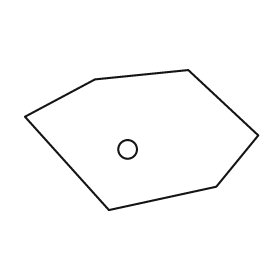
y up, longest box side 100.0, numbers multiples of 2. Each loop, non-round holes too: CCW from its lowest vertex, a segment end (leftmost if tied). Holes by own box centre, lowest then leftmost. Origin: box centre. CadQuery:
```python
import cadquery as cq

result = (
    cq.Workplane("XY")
    .moveTo(-14.0, -30.0)
    .lineTo(32.0, -20.0)
    .lineTo(50.0, 2.0)
    .lineTo(20.0, 30.0)
    .lineTo(-20.0, 26.0)
    .lineTo(-50.0, 10.0)
    .close()
    .moveTo(-6.0, -4.0)
    .circle(4.0)
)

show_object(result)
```